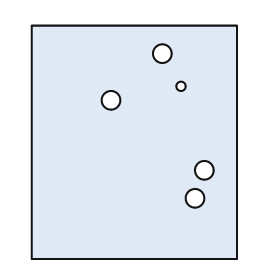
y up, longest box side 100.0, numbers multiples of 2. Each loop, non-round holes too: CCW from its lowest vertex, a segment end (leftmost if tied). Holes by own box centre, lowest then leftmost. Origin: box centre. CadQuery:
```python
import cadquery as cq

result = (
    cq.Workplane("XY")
    .moveTo(-44.0, -50.0)
    .lineTo(44.0, -50.0)
    .lineTo(44.0, 50.0)
    .lineTo(-44.0, 50.0)
    .close()
    .moveTo(26.0, -24.0)
    .circle(4.0)
    .moveTo(30.0, -12.0)
    .circle(4.0)
    .moveTo(-10.0, 18.0)
    .circle(4.0)
    .moveTo(20.0, 24.0)
    .circle(2.0)
    .moveTo(12.0, 38.0)
    .circle(4.0)
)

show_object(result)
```